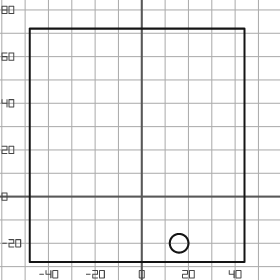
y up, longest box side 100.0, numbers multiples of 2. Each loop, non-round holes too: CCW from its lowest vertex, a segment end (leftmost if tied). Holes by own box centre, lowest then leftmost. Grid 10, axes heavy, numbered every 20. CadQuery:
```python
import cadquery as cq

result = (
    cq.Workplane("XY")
    .moveTo(-48.0, -28.0)
    .lineTo(44.0, -28.0)
    .lineTo(44.0, 72.0)
    .lineTo(-48.0, 72.0)
    .close()
    .moveTo(16.0, -20.0)
    .circle(4.0)
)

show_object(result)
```